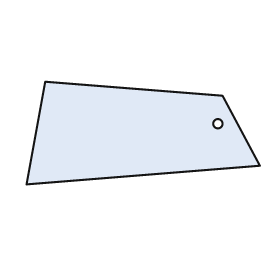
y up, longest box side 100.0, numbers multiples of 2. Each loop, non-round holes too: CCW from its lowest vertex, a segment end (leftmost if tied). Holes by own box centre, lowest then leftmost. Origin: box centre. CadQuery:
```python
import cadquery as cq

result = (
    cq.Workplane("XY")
    .moveTo(-50.0, -22.0)
    .lineTo(50.0, -14.0)
    .lineTo(34.0, 16.0)
    .lineTo(-42.0, 22.0)
    .close()
    .moveTo(32.0, 4.0)
    .circle(2.0)
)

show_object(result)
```